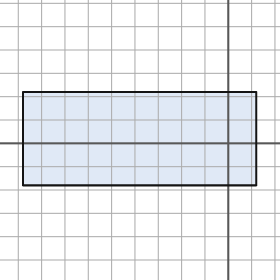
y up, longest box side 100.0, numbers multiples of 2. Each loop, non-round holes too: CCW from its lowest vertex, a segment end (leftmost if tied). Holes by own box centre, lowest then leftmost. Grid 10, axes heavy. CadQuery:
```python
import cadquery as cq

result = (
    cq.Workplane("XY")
    .moveTo(-88.0, -18.0)
    .lineTo(12.0, -18.0)
    .lineTo(12.0, 22.0)
    .lineTo(-88.0, 22.0)
    .close()
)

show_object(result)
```